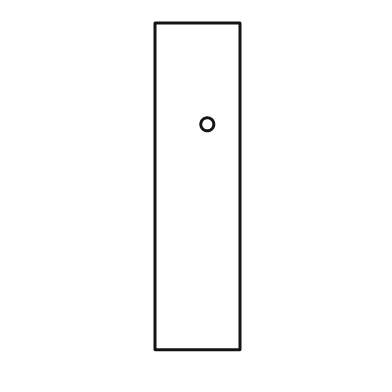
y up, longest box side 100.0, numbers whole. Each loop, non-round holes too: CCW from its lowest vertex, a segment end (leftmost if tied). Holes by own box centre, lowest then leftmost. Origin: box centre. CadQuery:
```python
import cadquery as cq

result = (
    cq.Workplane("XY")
    .moveTo(-13.0, -50.0)
    .lineTo(13.0, -50.0)
    .lineTo(13.0, 50.0)
    .lineTo(-13.0, 50.0)
    .close()
    .moveTo(3.0, 19.0)
    .circle(2.0)
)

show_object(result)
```